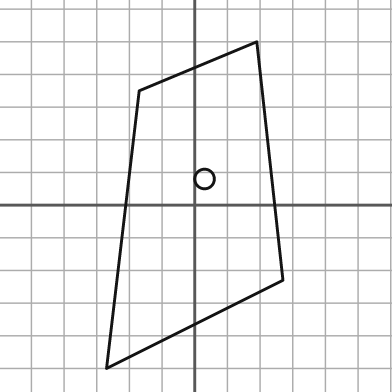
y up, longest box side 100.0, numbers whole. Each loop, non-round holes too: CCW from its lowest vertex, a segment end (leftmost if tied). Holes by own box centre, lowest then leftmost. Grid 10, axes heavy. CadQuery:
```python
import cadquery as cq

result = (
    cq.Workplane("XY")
    .moveTo(-27.0, -50.0)
    .lineTo(27.0, -23.0)
    .lineTo(19.0, 50.0)
    .lineTo(-17.0, 35.0)
    .close()
    .moveTo(3.0, 8.0)
    .circle(3.0)
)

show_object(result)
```